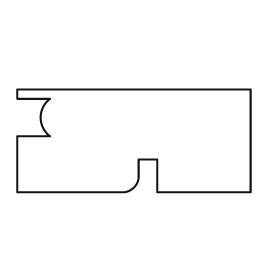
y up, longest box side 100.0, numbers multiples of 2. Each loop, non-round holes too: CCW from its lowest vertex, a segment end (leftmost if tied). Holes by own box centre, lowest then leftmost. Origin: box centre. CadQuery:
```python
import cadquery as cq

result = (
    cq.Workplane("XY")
    .moveTo(-50.0, -22.0)
    .lineTo(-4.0, -22.0)
    .threePointArc((0.0, -20.0), (2.0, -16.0))
    .lineTo(2.0, -8.0)
    .lineTo(10.0, -8.0)
    .lineTo(10.0, -22.0)
    .lineTo(50.0, -22.0)
    .lineTo(50.0, 22.0)
    .lineTo(-50.0, 22.0)
    .lineTo(-50.0, 18.0)
    .lineTo(-36.0, 18.0)
    .threePointArc((-40.0, 10.0), (-36.0, 2.0))
    .lineTo(-50.0, 2.0)
    .close()
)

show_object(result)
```